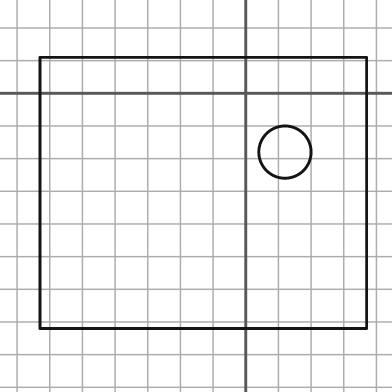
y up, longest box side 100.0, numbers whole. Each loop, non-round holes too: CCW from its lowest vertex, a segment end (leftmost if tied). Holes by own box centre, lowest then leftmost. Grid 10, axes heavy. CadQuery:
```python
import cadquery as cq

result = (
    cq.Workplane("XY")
    .moveTo(-63.0, -72.0)
    .lineTo(37.0, -72.0)
    .lineTo(37.0, 11.0)
    .lineTo(-63.0, 11.0)
    .close()
    .moveTo(12.0, -18.0)
    .circle(8.0)
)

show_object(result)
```